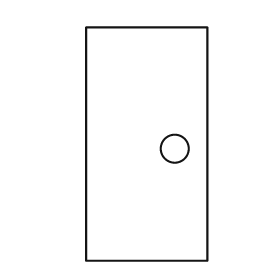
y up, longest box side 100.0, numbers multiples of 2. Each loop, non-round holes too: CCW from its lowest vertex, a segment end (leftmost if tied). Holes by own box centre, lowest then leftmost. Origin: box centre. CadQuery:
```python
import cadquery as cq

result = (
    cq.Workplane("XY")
    .moveTo(-26.0, -50.0)
    .lineTo(26.0, -50.0)
    .lineTo(26.0, 50.0)
    .lineTo(-26.0, 50.0)
    .close()
    .moveTo(12.0, -2.0)
    .circle(6.0)
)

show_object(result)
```